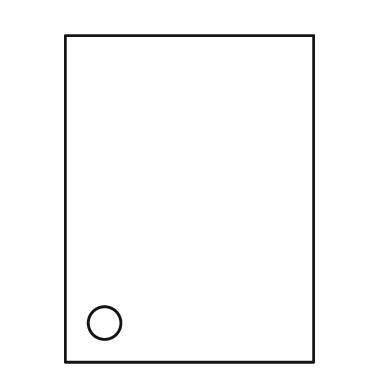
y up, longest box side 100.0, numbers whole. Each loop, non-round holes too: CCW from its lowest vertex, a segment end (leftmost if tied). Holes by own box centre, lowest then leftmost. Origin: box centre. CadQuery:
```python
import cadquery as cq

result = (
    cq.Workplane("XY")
    .moveTo(-38.0, -50.0)
    .lineTo(38.0, -50.0)
    .lineTo(38.0, 50.0)
    .lineTo(-38.0, 50.0)
    .close()
    .moveTo(-26.0, -38.0)
    .circle(5.0)
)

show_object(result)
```